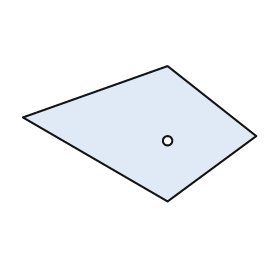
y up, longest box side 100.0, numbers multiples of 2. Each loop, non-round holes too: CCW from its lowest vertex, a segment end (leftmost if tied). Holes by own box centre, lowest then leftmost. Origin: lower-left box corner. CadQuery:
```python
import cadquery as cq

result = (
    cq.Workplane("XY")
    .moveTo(62.0, 0.0)
    .lineTo(100.0, 28.0)
    .lineTo(62.0, 58.0)
    .lineTo(0.0, 36.0)
    .close()
    .moveTo(62.0, 26.0)
    .circle(2.0)
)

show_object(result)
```